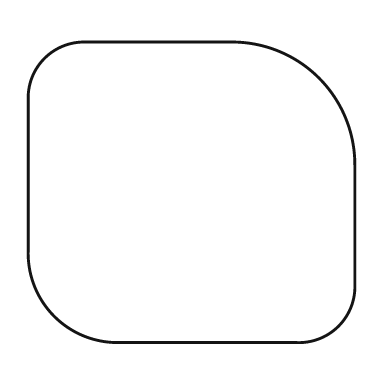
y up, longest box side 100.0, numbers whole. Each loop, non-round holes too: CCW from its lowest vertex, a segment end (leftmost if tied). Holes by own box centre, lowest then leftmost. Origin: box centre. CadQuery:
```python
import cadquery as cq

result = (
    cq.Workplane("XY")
    .moveTo(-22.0, -46.0)
    .lineTo(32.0, -46.0)
    .threePointArc((45.0, -41.0), (50.0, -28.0))
    .lineTo(50.0, 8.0)
    .threePointArc((39.0, 35.0), (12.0, 46.0))
    .lineTo(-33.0, 46.0)
    .threePointArc((-45.0, 41.0), (-50.0, 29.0))
    .lineTo(-50.0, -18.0)
    .threePointArc((-42.0, -38.0), (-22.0, -46.0))
    .close()
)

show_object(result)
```